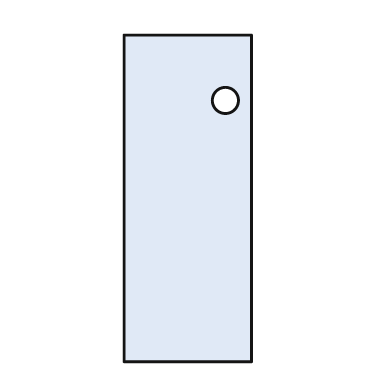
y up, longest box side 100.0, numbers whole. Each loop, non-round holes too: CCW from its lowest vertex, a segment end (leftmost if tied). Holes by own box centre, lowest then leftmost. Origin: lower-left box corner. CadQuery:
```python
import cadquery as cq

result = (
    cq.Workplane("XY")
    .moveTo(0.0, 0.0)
    .lineTo(39.0, 0.0)
    .lineTo(39.0, 100.0)
    .lineTo(0.0, 100.0)
    .close()
    .moveTo(31.0, 80.0)
    .circle(4.0)
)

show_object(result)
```